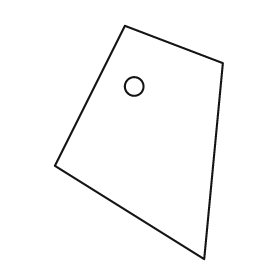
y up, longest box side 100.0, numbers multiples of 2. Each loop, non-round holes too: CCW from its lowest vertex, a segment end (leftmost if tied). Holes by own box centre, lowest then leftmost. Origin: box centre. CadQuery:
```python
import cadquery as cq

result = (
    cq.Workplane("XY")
    .moveTo(28.0, -50.0)
    .lineTo(36.0, 34.0)
    .lineTo(-6.0, 50.0)
    .lineTo(-36.0, -10.0)
    .close()
    .moveTo(-2.0, 24.0)
    .circle(4.0)
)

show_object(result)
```